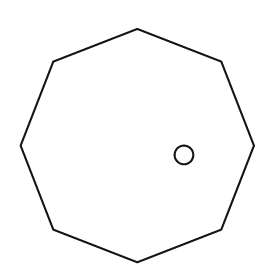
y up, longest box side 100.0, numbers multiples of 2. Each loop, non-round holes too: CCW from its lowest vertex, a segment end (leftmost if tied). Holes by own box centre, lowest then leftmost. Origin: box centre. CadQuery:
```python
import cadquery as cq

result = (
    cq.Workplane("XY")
    .moveTo(0.0, -50.0)
    .lineTo(36.0, -36.0)
    .lineTo(50.0, 0.0)
    .lineTo(36.0, 36.0)
    .lineTo(0.0, 50.0)
    .lineTo(-36.0, 36.0)
    .lineTo(-50.0, 0.0)
    .lineTo(-36.0, -36.0)
    .close()
    .moveTo(20.0, -4.0)
    .circle(4.0)
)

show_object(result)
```